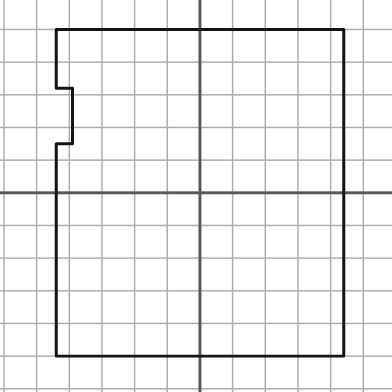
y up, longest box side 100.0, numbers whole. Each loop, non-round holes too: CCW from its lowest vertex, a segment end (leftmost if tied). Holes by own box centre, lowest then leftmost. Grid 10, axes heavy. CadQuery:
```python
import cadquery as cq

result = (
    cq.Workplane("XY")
    .moveTo(-44.0, -50.0)
    .lineTo(44.0, -50.0)
    .lineTo(44.0, 50.0)
    .lineTo(-44.0, 50.0)
    .lineTo(-44.0, 32.0)
    .lineTo(-39.0, 32.0)
    .lineTo(-39.0, 15.0)
    .lineTo(-44.0, 15.0)
    .close()
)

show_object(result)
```